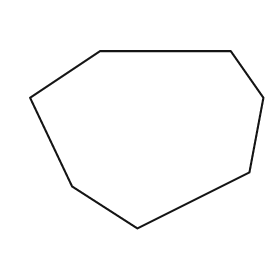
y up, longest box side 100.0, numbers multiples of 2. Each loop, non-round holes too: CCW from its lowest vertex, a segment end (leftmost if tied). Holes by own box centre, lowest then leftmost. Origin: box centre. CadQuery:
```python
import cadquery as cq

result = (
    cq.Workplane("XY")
    .moveTo(-4.0, -38.0)
    .lineTo(44.0, -14.0)
    .lineTo(50.0, 18.0)
    .lineTo(36.0, 38.0)
    .lineTo(-20.0, 38.0)
    .lineTo(-50.0, 18.0)
    .lineTo(-32.0, -20.0)
    .close()
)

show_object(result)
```